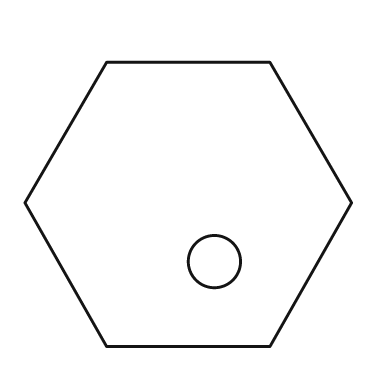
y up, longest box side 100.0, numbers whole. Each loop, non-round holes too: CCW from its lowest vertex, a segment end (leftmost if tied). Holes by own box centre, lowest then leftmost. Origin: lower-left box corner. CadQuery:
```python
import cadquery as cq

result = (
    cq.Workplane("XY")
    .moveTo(25.0, 0.0)
    .lineTo(75.0, 0.0)
    .lineTo(100.0, 44.0)
    .lineTo(75.0, 87.0)
    .lineTo(25.0, 87.0)
    .lineTo(0.0, 44.0)
    .close()
    .moveTo(58.0, 26.0)
    .circle(8.0)
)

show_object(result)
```